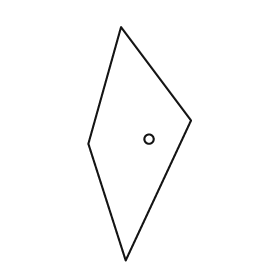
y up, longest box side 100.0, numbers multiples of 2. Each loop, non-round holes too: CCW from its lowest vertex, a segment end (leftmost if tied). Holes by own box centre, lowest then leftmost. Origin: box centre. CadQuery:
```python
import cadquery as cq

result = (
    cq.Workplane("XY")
    .moveTo(-6.0, -50.0)
    .lineTo(22.0, 10.0)
    .lineTo(-8.0, 50.0)
    .lineTo(-22.0, 0.0)
    .close()
    .moveTo(4.0, 2.0)
    .circle(2.0)
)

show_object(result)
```